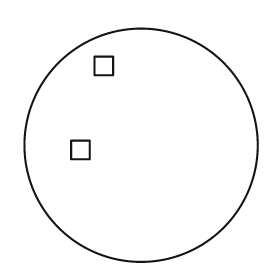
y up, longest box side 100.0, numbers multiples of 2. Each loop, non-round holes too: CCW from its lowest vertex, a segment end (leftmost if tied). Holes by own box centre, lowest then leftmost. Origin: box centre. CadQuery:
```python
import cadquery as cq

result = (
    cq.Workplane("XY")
    .moveTo(0.0, 0.0)
    .circle(50.0)
    .moveTo(-30.0, -6.0)
    .lineTo(-22.0, -6.0)
    .lineTo(-22.0, 2.0)
    .lineTo(-30.0, 2.0)
    .close()
    .moveTo(-20.0, 30.0)
    .lineTo(-12.0, 30.0)
    .lineTo(-12.0, 38.0)
    .lineTo(-20.0, 38.0)
    .close()
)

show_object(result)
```